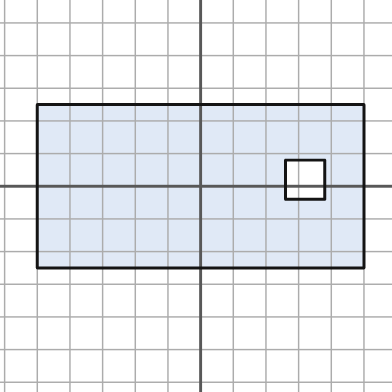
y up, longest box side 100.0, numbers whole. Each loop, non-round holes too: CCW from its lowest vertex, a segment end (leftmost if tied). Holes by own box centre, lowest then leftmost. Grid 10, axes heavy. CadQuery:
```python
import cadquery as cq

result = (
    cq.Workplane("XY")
    .moveTo(-50.0, -25.0)
    .lineTo(50.0, -25.0)
    .lineTo(50.0, 25.0)
    .lineTo(-50.0, 25.0)
    .close()
    .moveTo(26.0, -4.0)
    .lineTo(38.0, -4.0)
    .lineTo(38.0, 8.0)
    .lineTo(26.0, 8.0)
    .close()
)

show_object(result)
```